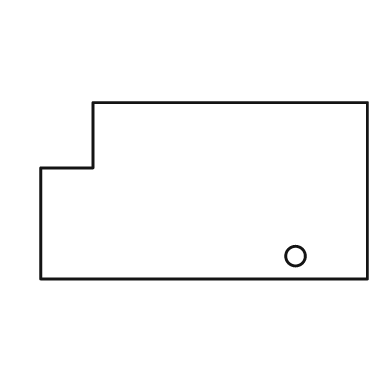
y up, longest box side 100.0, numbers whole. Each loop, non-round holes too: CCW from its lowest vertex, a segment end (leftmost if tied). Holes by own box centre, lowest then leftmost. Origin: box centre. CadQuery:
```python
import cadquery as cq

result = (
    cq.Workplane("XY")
    .moveTo(-50.0, -27.0)
    .lineTo(50.0, -27.0)
    .lineTo(50.0, 27.0)
    .lineTo(-34.0, 27.0)
    .lineTo(-34.0, 7.0)
    .lineTo(-50.0, 7.0)
    .close()
    .moveTo(28.0, -20.0)
    .circle(3.0)
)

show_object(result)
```